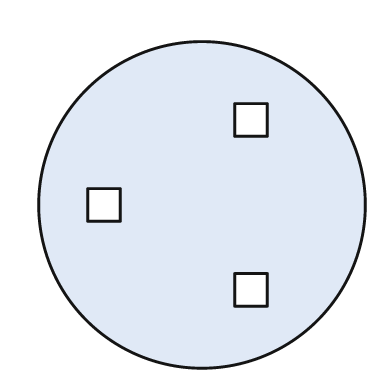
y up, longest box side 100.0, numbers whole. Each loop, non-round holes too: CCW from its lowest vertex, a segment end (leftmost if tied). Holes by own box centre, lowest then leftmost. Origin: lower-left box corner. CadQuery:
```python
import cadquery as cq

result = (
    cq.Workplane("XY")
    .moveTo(50.0, 50.0)
    .circle(50.0)
    .moveTo(60.0, 19.0)
    .lineTo(70.0, 19.0)
    .lineTo(70.0, 29.0)
    .lineTo(60.0, 29.0)
    .close()
    .moveTo(15.0, 45.0)
    .lineTo(25.0, 45.0)
    .lineTo(25.0, 55.0)
    .lineTo(15.0, 55.0)
    .close()
    .moveTo(60.0, 71.0)
    .lineTo(70.0, 71.0)
    .lineTo(70.0, 81.0)
    .lineTo(60.0, 81.0)
    .close()
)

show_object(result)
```